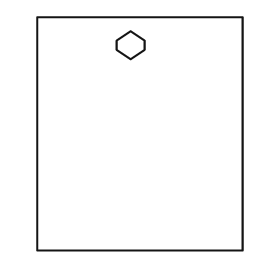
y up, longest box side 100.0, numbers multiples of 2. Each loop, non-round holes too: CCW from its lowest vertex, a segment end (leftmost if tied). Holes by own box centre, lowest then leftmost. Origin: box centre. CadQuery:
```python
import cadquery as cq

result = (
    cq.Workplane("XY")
    .moveTo(-44.0, -50.0)
    .lineTo(44.0, -50.0)
    .lineTo(44.0, 50.0)
    .lineTo(-44.0, 50.0)
    .close()
    .moveTo(-4.0, 32.0)
    .lineTo(2.0, 36.0)
    .lineTo(2.0, 40.0)
    .lineTo(-4.0, 44.0)
    .lineTo(-10.0, 40.0)
    .lineTo(-10.0, 36.0)
    .close()
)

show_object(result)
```